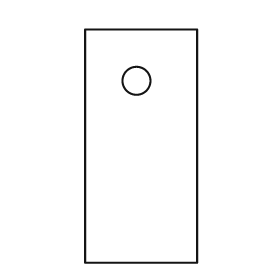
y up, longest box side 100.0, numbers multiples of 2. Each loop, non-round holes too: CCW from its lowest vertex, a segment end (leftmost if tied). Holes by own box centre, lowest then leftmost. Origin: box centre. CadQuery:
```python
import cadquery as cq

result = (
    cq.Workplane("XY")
    .moveTo(-24.0, -50.0)
    .lineTo(24.0, -50.0)
    .lineTo(24.0, 50.0)
    .lineTo(-24.0, 50.0)
    .close()
    .moveTo(-2.0, 28.0)
    .circle(6.0)
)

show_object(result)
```